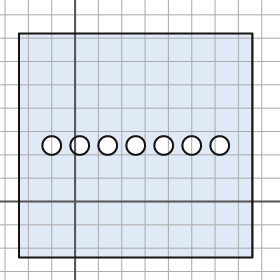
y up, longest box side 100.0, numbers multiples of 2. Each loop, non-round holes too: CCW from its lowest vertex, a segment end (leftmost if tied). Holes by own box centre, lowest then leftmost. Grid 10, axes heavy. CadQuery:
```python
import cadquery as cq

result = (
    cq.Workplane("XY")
    .moveTo(-24.0, -24.0)
    .lineTo(76.0, -24.0)
    .lineTo(76.0, 72.0)
    .lineTo(-24.0, 72.0)
    .close()
    .moveTo(-10.0, 24.0)
    .circle(4.0)
    .moveTo(2.0, 24.0)
    .circle(4.0)
    .moveTo(14.0, 24.0)
    .circle(4.0)
    .moveTo(26.0, 24.0)
    .circle(4.0)
    .moveTo(38.0, 24.0)
    .circle(4.0)
    .moveTo(50.0, 24.0)
    .circle(4.0)
    .moveTo(62.0, 24.0)
    .circle(4.0)
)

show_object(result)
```